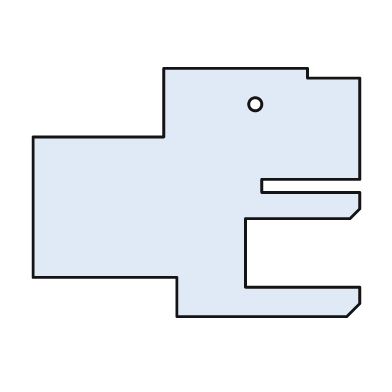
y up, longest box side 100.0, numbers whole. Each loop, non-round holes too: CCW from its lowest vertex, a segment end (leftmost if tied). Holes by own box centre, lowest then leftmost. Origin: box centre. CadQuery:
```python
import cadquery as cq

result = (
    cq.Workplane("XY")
    .moveTo(-6.0, -38.0)
    .lineTo(46.0, -38.0)
    .lineTo(50.0, -34.0)
    .lineTo(50.0, -29.0)
    .lineTo(15.0, -29.0)
    .lineTo(15.0, -8.0)
    .lineTo(47.0, -8.0)
    .lineTo(50.0, -5.0)
    .lineTo(50.0, 0.0)
    .lineTo(20.0, 0.0)
    .lineTo(20.0, 4.0)
    .lineTo(50.0, 4.0)
    .lineTo(50.0, 35.0)
    .lineTo(34.0, 35.0)
    .lineTo(34.0, 38.0)
    .lineTo(-10.0, 38.0)
    .lineTo(-10.0, 17.0)
    .lineTo(-50.0, 17.0)
    .lineTo(-50.0, -26.0)
    .lineTo(-6.0, -26.0)
    .close()
    .moveTo(18.0, 27.0)
    .circle(2.0)
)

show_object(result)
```